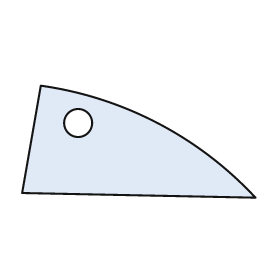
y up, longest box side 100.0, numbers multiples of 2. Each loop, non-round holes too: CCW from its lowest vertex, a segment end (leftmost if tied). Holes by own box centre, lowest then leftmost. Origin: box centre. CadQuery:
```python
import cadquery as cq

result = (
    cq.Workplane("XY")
    .moveTo(50.0, -24.0)
    .threePointArc((8.0, 8.0), (-42.0, 24.0))
    .lineTo(-50.0, -22.0)
    .close()
    .moveTo(-26.0, 8.0)
    .circle(6.0)
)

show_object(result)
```